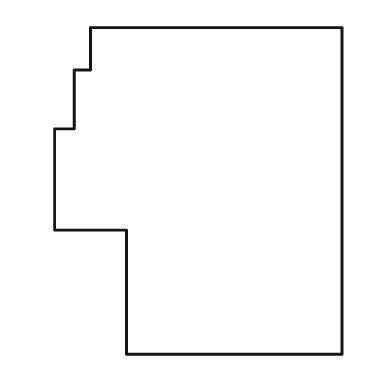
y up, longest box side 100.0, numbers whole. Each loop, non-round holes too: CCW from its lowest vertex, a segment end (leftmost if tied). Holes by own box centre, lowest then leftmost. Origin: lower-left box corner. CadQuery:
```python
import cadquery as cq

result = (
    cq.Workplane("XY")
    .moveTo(22.0, 0.0)
    .lineTo(88.0, 0.0)
    .lineTo(88.0, 100.0)
    .lineTo(11.0, 100.0)
    .lineTo(11.0, 87.0)
    .lineTo(6.0, 87.0)
    .lineTo(6.0, 69.0)
    .lineTo(0.0, 69.0)
    .lineTo(0.0, 38.0)
    .lineTo(22.0, 38.0)
    .close()
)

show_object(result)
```